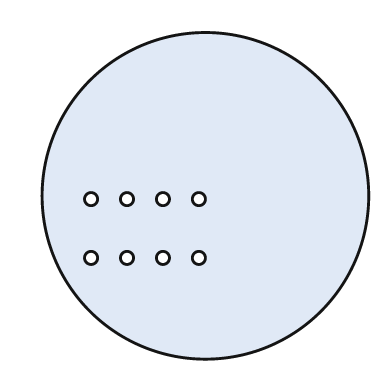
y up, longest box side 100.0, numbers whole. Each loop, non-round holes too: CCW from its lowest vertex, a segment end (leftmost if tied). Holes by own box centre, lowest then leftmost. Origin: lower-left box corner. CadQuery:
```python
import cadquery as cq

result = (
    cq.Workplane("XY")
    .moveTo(50.0, 50.0)
    .circle(50.0)
    .moveTo(15.0, 31.0)
    .circle(2.0)
    .moveTo(26.0, 31.0)
    .circle(2.0)
    .moveTo(37.0, 31.0)
    .circle(2.0)
    .moveTo(48.0, 31.0)
    .circle(2.0)
    .moveTo(15.0, 49.0)
    .circle(2.0)
    .moveTo(26.0, 49.0)
    .circle(2.0)
    .moveTo(37.0, 49.0)
    .circle(2.0)
    .moveTo(48.0, 49.0)
    .circle(2.0)
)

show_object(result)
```